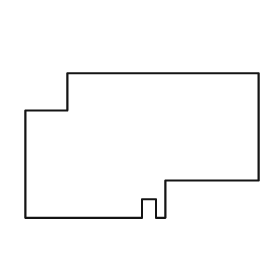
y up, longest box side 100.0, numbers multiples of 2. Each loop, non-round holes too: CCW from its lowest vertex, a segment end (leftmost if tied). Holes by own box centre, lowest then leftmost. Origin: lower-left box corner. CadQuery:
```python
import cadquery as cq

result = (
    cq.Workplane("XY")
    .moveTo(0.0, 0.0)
    .lineTo(50.0, 0.0)
    .lineTo(50.0, 8.0)
    .lineTo(56.0, 8.0)
    .lineTo(56.0, 0.0)
    .lineTo(60.0, 0.0)
    .lineTo(60.0, 16.0)
    .lineTo(100.0, 16.0)
    .lineTo(100.0, 62.0)
    .lineTo(18.0, 62.0)
    .lineTo(18.0, 46.0)
    .lineTo(0.0, 46.0)
    .close()
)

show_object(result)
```